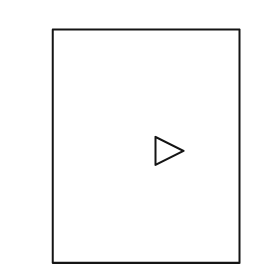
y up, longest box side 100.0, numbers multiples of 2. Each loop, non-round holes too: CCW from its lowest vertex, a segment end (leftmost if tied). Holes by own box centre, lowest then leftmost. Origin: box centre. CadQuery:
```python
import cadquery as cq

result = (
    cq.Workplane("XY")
    .moveTo(-40.0, -50.0)
    .lineTo(40.0, -50.0)
    .lineTo(40.0, 50.0)
    .lineTo(-40.0, 50.0)
    .close()
    .moveTo(4.0, -8.0)
    .lineTo(16.0, -2.0)
    .lineTo(4.0, 4.0)
    .close()
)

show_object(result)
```